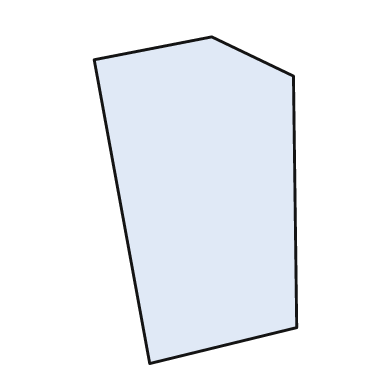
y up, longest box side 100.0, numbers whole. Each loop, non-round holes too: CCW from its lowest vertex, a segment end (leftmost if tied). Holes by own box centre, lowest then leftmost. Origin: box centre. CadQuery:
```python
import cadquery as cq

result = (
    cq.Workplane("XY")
    .moveTo(-14.0, -50.0)
    .lineTo(31.0, -39.0)
    .lineTo(30.0, 38.0)
    .lineTo(5.0, 50.0)
    .lineTo(-31.0, 43.0)
    .close()
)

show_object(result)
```